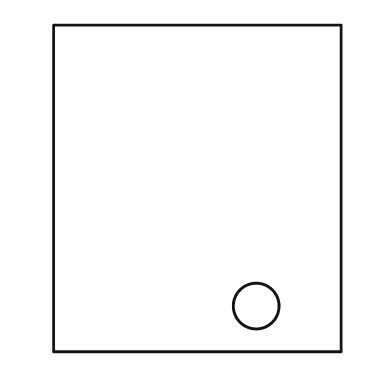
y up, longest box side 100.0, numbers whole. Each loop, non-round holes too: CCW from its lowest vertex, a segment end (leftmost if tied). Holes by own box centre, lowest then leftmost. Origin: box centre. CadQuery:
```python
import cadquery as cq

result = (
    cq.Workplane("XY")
    .moveTo(-44.0, -50.0)
    .lineTo(44.0, -50.0)
    .lineTo(44.0, 50.0)
    .lineTo(-44.0, 50.0)
    .close()
    .moveTo(18.0, -36.0)
    .circle(7.0)
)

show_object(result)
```